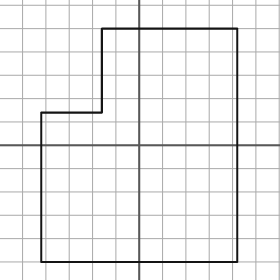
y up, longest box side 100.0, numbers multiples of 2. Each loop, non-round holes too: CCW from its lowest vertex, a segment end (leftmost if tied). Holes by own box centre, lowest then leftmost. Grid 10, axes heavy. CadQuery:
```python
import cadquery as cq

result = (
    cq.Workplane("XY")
    .moveTo(-42.0, -50.0)
    .lineTo(42.0, -50.0)
    .lineTo(42.0, 50.0)
    .lineTo(-16.0, 50.0)
    .lineTo(-16.0, 14.0)
    .lineTo(-42.0, 14.0)
    .close()
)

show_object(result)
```